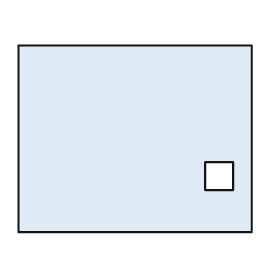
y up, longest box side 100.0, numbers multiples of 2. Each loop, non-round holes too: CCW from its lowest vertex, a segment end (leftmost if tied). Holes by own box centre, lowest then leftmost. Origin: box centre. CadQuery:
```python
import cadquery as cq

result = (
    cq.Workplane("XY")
    .moveTo(-50.0, -40.0)
    .lineTo(50.0, -40.0)
    .lineTo(50.0, 40.0)
    .lineTo(-50.0, 40.0)
    .close()
    .moveTo(30.0, -22.0)
    .lineTo(42.0, -22.0)
    .lineTo(42.0, -10.0)
    .lineTo(30.0, -10.0)
    .close()
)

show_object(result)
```